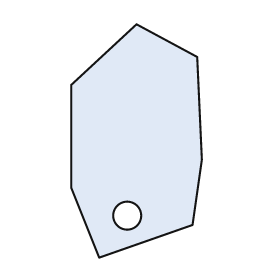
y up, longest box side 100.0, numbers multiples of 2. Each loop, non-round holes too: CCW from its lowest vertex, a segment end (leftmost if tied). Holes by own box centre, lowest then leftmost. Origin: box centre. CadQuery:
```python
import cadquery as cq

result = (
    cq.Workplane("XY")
    .moveTo(-16.0, -50.0)
    .lineTo(24.0, -36.0)
    .lineTo(28.0, -8.0)
    .lineTo(26.0, 36.0)
    .lineTo(0.0, 50.0)
    .lineTo(-28.0, 24.0)
    .lineTo(-28.0, -20.0)
    .close()
    .moveTo(-4.0, -32.0)
    .circle(6.0)
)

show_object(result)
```